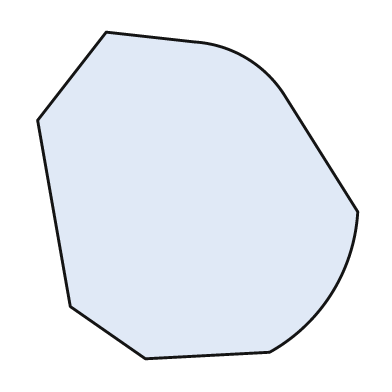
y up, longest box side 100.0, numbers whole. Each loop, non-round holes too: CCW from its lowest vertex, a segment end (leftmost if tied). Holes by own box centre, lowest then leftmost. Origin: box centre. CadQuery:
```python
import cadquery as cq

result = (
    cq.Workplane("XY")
    .moveTo(-16.0, -50.0)
    .lineTo(22.0, -48.0)
    .threePointArc((41.0, -30.0), (49.0, -5.0))
    .lineTo(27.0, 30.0)
    .threePointArc((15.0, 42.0), (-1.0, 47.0))
    .lineTo(-28.0, 50.0)
    .lineTo(-49.0, 23.0)
    .lineTo(-39.0, -34.0)
    .close()
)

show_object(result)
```